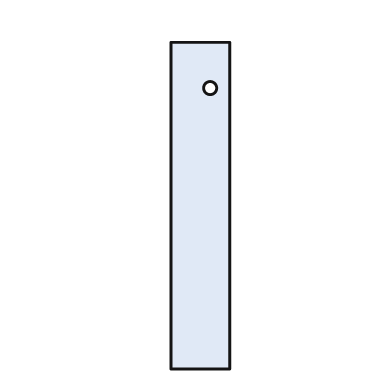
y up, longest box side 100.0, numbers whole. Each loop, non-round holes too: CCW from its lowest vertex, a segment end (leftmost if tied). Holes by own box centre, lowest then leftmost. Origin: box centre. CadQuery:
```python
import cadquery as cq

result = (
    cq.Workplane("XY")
    .moveTo(-9.0, -50.0)
    .lineTo(9.0, -50.0)
    .lineTo(9.0, 50.0)
    .lineTo(-9.0, 50.0)
    .close()
    .moveTo(3.0, 36.0)
    .circle(2.0)
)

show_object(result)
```